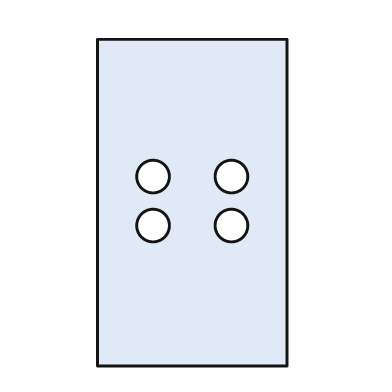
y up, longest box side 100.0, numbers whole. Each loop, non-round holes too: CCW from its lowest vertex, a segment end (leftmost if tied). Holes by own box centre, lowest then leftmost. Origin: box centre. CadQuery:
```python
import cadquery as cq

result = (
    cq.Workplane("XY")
    .moveTo(-29.0, -50.0)
    .lineTo(29.0, -50.0)
    .lineTo(29.0, 50.0)
    .lineTo(-29.0, 50.0)
    .close()
    .moveTo(-12.0, -7.0)
    .circle(5.0)
    .moveTo(12.0, -7.0)
    .circle(5.0)
    .moveTo(-12.0, 8.0)
    .circle(5.0)
    .moveTo(12.0, 8.0)
    .circle(5.0)
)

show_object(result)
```